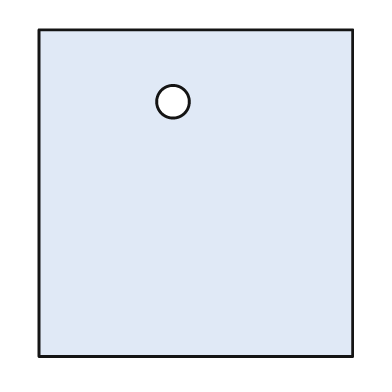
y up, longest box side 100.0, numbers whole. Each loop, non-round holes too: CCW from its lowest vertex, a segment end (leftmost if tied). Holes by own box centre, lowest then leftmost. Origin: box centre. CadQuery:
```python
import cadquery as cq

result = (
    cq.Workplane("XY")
    .moveTo(-48.0, -50.0)
    .lineTo(48.0, -50.0)
    .lineTo(48.0, 50.0)
    .lineTo(-48.0, 50.0)
    .close()
    .moveTo(-7.0, 28.0)
    .circle(5.0)
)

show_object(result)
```